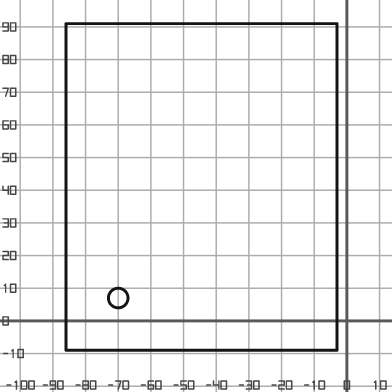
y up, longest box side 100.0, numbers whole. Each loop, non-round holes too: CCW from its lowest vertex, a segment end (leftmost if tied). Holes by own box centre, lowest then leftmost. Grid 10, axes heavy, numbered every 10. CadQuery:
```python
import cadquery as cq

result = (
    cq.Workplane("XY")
    .moveTo(-86.0, -9.0)
    .lineTo(-3.0, -9.0)
    .lineTo(-3.0, 91.0)
    .lineTo(-86.0, 91.0)
    .close()
    .moveTo(-70.0, 7.0)
    .circle(3.0)
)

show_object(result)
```